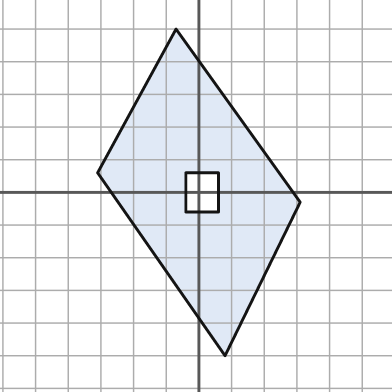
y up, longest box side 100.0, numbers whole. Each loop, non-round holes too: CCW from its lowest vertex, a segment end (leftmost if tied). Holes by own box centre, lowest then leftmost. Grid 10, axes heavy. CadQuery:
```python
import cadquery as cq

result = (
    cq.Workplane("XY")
    .moveTo(8.0, -50.0)
    .lineTo(31.0, -3.0)
    .lineTo(-7.0, 50.0)
    .lineTo(-31.0, 6.0)
    .close()
    .moveTo(-4.0, -6.0)
    .lineTo(6.0, -6.0)
    .lineTo(6.0, 6.0)
    .lineTo(-4.0, 6.0)
    .close()
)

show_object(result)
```